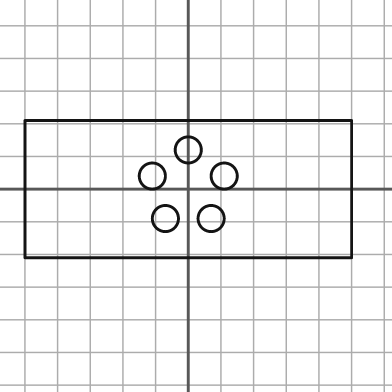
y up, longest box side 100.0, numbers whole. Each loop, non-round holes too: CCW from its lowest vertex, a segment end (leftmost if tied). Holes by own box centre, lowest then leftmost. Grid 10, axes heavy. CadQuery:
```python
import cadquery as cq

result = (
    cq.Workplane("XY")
    .moveTo(-50.0, -21.0)
    .lineTo(50.0, -21.0)
    .lineTo(50.0, 21.0)
    .lineTo(-50.0, 21.0)
    .close()
    .moveTo(-7.0, -9.0)
    .circle(4.0)
    .moveTo(7.0, -9.0)
    .circle(4.0)
    .moveTo(-11.0, 4.0)
    .circle(4.0)
    .moveTo(11.0, 4.0)
    .circle(4.0)
    .moveTo(0.0, 12.0)
    .circle(4.0)
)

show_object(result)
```